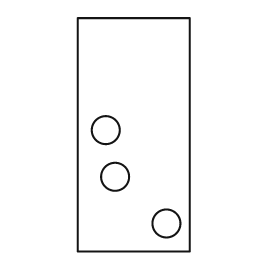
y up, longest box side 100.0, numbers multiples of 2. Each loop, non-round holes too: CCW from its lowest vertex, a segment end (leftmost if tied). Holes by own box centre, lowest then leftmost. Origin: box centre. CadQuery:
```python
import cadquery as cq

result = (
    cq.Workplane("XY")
    .moveTo(-24.0, -50.0)
    .lineTo(24.0, -50.0)
    .lineTo(24.0, 50.0)
    .lineTo(-24.0, 50.0)
    .close()
    .moveTo(14.0, -38.0)
    .circle(6.0)
    .moveTo(-8.0, -18.0)
    .circle(6.0)
    .moveTo(-12.0, 2.0)
    .circle(6.0)
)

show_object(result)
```